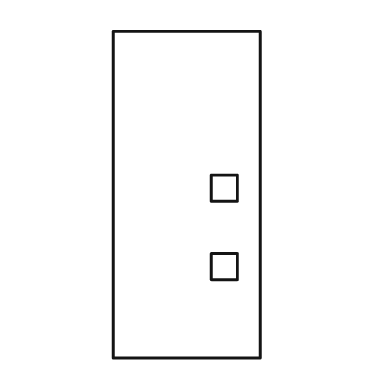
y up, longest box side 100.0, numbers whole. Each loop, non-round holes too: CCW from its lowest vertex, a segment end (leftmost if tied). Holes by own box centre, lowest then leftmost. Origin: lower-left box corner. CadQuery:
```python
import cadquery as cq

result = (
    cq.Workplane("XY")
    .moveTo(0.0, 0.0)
    .lineTo(45.0, 0.0)
    .lineTo(45.0, 100.0)
    .lineTo(0.0, 100.0)
    .close()
    .moveTo(30.0, 24.0)
    .lineTo(38.0, 24.0)
    .lineTo(38.0, 32.0)
    .lineTo(30.0, 32.0)
    .close()
    .moveTo(30.0, 48.0)
    .lineTo(38.0, 48.0)
    .lineTo(38.0, 56.0)
    .lineTo(30.0, 56.0)
    .close()
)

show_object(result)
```